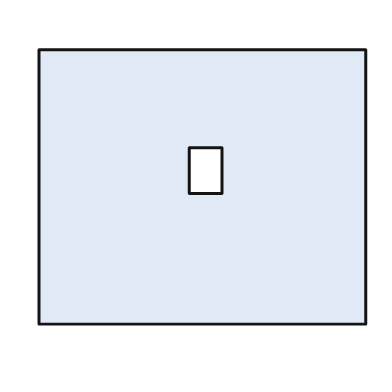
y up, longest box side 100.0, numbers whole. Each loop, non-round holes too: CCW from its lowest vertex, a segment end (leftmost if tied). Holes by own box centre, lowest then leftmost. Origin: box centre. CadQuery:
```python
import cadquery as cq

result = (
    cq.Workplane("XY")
    .moveTo(-50.0, -42.0)
    .lineTo(50.0, -42.0)
    .lineTo(50.0, 42.0)
    .lineTo(-50.0, 42.0)
    .close()
    .moveTo(-4.0, -2.0)
    .lineTo(6.0, -2.0)
    .lineTo(6.0, 12.0)
    .lineTo(-4.0, 12.0)
    .close()
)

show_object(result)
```